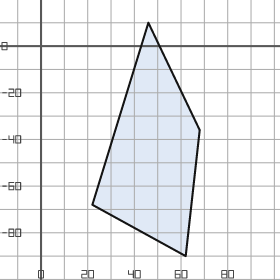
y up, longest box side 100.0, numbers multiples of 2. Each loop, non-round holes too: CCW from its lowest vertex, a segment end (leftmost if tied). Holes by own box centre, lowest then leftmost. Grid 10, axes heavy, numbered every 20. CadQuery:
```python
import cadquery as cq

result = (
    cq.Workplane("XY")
    .moveTo(62.0, -90.0)
    .lineTo(68.0, -36.0)
    .lineTo(46.0, 10.0)
    .lineTo(22.0, -68.0)
    .close()
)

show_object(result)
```